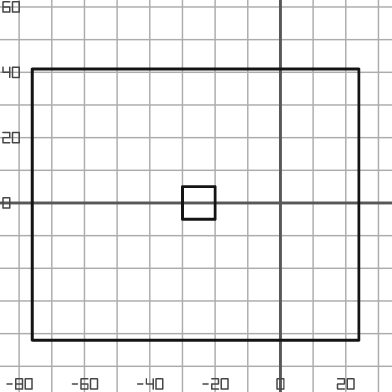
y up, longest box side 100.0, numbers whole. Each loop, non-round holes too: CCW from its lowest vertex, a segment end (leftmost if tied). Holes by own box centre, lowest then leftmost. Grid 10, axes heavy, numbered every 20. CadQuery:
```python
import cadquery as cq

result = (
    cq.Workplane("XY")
    .moveTo(-76.0, -42.0)
    .lineTo(24.0, -42.0)
    .lineTo(24.0, 41.0)
    .lineTo(-76.0, 41.0)
    .close()
    .moveTo(-30.0, -5.0)
    .lineTo(-20.0, -5.0)
    .lineTo(-20.0, 5.0)
    .lineTo(-30.0, 5.0)
    .close()
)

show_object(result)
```